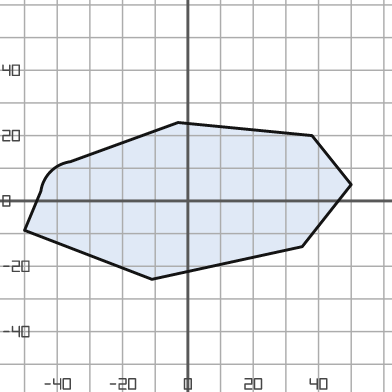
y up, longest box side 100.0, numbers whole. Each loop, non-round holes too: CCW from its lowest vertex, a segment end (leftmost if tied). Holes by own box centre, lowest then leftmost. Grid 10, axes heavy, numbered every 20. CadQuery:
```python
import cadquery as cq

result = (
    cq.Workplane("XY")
    .moveTo(-11.0, -24.0)
    .lineTo(35.0, -14.0)
    .lineTo(50.0, 5.0)
    .lineTo(38.0, 20.0)
    .lineTo(-3.0, 24.0)
    .lineTo(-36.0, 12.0)
    .threePointArc((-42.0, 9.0), (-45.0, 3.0))
    .lineTo(-50.0, -9.0)
    .close()
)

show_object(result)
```